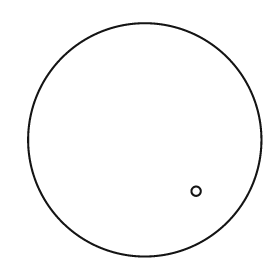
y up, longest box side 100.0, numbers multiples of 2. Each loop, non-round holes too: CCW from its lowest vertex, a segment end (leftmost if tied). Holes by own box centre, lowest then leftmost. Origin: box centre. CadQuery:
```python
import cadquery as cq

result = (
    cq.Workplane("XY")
    .moveTo(0.0, 0.0)
    .circle(50.0)
    .moveTo(22.0, -22.0)
    .circle(2.0)
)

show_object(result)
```